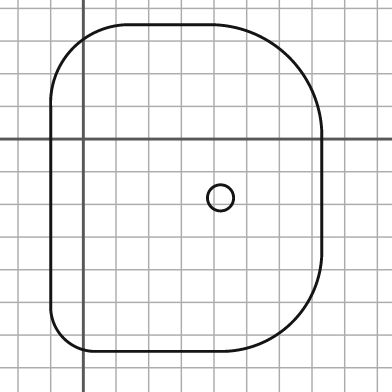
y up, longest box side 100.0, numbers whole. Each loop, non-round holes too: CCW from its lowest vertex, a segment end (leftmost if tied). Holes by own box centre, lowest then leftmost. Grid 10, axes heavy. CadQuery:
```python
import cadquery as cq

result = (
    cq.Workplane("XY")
    .moveTo(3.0, -65.0)
    .lineTo(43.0, -65.0)
    .threePointArc((64.0, -56.0), (73.0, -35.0))
    .lineTo(73.0, 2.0)
    .threePointArc((63.0, 25.0), (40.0, 35.0))
    .lineTo(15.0, 35.0)
    .threePointArc((-3.0, 28.0), (-10.0, 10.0))
    .lineTo(-10.0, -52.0)
    .threePointArc((-6.0, -61.0), (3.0, -65.0))
    .close()
    .moveTo(42.0, -18.0)
    .circle(4.0)
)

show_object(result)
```